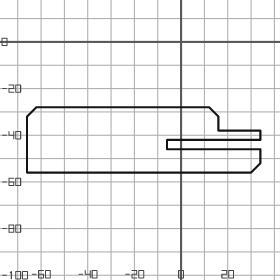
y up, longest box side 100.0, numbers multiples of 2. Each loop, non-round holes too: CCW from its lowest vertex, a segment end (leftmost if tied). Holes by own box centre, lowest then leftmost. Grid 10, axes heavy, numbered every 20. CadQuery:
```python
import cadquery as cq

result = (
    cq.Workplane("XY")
    .moveTo(-66.0, -56.0)
    .lineTo(30.0, -56.0)
    .lineTo(34.0, -52.0)
    .lineTo(34.0, -46.0)
    .lineTo(-6.0, -46.0)
    .lineTo(-6.0, -42.0)
    .lineTo(34.0, -42.0)
    .lineTo(34.0, -38.0)
    .lineTo(16.0, -38.0)
    .lineTo(16.0, -32.0)
    .lineTo(12.0, -28.0)
    .lineTo(-62.0, -28.0)
    .lineTo(-66.0, -32.0)
    .close()
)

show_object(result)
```